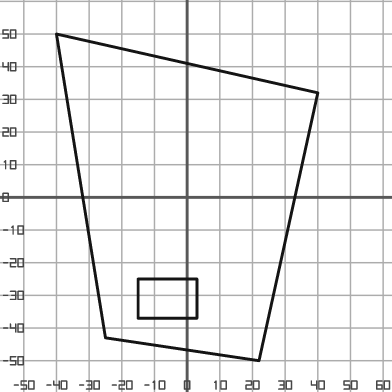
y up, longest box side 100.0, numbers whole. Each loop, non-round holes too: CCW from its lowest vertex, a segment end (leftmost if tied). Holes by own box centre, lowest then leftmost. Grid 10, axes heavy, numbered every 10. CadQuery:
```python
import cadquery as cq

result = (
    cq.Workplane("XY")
    .moveTo(22.0, -50.0)
    .lineTo(40.0, 32.0)
    .lineTo(-40.0, 50.0)
    .lineTo(-25.0, -43.0)
    .close()
    .moveTo(-15.0, -37.0)
    .lineTo(3.0, -37.0)
    .lineTo(3.0, -25.0)
    .lineTo(-15.0, -25.0)
    .close()
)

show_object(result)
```